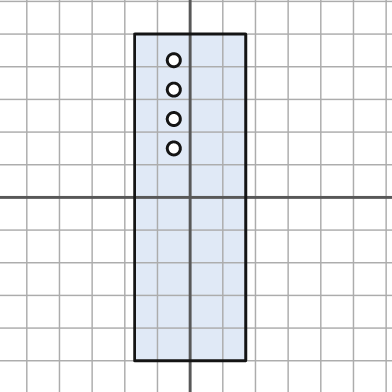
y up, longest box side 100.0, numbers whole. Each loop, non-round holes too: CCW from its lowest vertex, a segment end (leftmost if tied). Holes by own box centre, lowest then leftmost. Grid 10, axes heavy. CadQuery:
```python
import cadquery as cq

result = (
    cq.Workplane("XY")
    .moveTo(-17.0, -50.0)
    .lineTo(17.0, -50.0)
    .lineTo(17.0, 50.0)
    .lineTo(-17.0, 50.0)
    .close()
    .moveTo(-5.0, 15.0)
    .circle(2.0)
    .moveTo(-5.0, 24.0)
    .circle(2.0)
    .moveTo(-5.0, 33.0)
    .circle(2.0)
    .moveTo(-5.0, 42.0)
    .circle(2.0)
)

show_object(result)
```